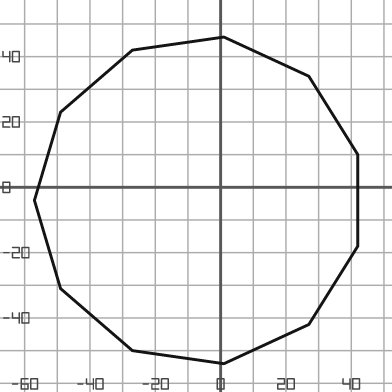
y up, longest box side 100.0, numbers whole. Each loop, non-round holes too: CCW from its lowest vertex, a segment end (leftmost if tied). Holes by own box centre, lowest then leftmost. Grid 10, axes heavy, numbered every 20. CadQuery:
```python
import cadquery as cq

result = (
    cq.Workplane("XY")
    .moveTo(1.0, -54.0)
    .lineTo(27.0, -42.0)
    .lineTo(42.0, -18.0)
    .lineTo(42.0, 10.0)
    .lineTo(27.0, 34.0)
    .lineTo(1.0, 46.0)
    .lineTo(-27.0, 42.0)
    .lineTo(-49.0, 23.0)
    .lineTo(-57.0, -4.0)
    .lineTo(-49.0, -31.0)
    .lineTo(-27.0, -50.0)
    .close()
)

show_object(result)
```